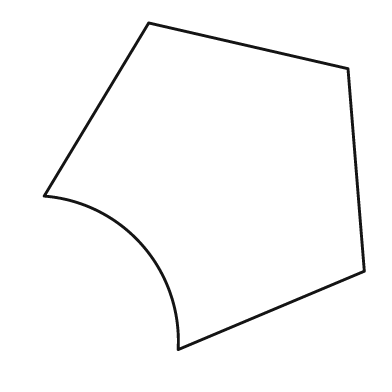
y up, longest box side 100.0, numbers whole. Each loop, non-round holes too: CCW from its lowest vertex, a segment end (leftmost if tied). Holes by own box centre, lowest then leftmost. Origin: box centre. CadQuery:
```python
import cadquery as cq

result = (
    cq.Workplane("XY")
    .moveTo(-8.0, -50.0)
    .lineTo(49.0, -26.0)
    .lineTo(44.0, 36.0)
    .lineTo(-17.0, 50.0)
    .lineTo(-49.0, -3.0)
    .threePointArc((-19.0, -18.0), (-8.0, -50.0))
    .close()
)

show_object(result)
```